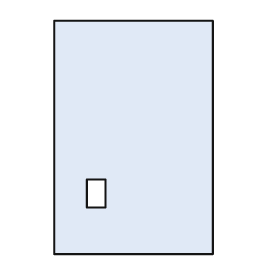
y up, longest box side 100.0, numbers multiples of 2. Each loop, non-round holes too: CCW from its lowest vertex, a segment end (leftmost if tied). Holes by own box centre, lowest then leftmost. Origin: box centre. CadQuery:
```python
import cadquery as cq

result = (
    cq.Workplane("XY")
    .moveTo(-34.0, -50.0)
    .lineTo(34.0, -50.0)
    .lineTo(34.0, 50.0)
    .lineTo(-34.0, 50.0)
    .close()
    .moveTo(-20.0, -30.0)
    .lineTo(-12.0, -30.0)
    .lineTo(-12.0, -18.0)
    .lineTo(-20.0, -18.0)
    .close()
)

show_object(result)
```